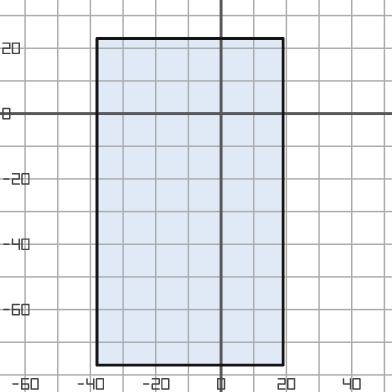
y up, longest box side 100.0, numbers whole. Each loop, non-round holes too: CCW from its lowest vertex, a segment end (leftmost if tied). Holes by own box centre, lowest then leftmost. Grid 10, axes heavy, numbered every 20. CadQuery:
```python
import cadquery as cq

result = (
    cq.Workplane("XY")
    .moveTo(-38.0, -77.0)
    .lineTo(19.0, -77.0)
    .lineTo(19.0, 23.0)
    .lineTo(-38.0, 23.0)
    .close()
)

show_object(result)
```